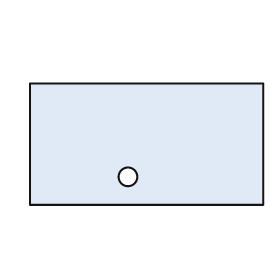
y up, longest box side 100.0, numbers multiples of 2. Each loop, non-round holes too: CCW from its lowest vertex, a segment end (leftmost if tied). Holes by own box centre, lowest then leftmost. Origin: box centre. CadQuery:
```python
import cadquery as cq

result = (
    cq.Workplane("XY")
    .moveTo(-50.0, -26.0)
    .lineTo(50.0, -26.0)
    .lineTo(50.0, 26.0)
    .lineTo(-50.0, 26.0)
    .close()
    .moveTo(-8.0, -14.0)
    .circle(4.0)
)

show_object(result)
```